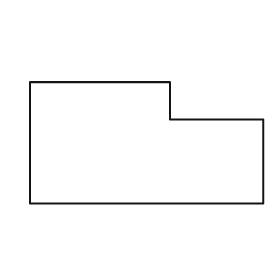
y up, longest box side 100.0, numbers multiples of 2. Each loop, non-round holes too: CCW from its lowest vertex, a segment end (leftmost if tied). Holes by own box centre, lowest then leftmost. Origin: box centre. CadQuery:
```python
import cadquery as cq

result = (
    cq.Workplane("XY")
    .moveTo(-50.0, -26.0)
    .lineTo(50.0, -26.0)
    .lineTo(50.0, 10.0)
    .lineTo(10.0, 10.0)
    .lineTo(10.0, 26.0)
    .lineTo(-50.0, 26.0)
    .close()
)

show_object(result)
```